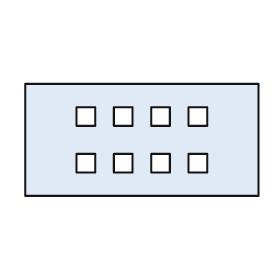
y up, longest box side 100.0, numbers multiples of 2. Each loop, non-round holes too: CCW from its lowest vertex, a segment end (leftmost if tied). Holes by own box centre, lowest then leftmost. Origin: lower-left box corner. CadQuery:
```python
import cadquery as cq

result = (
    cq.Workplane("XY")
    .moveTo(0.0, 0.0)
    .lineTo(100.0, 0.0)
    .lineTo(100.0, 48.0)
    .lineTo(0.0, 48.0)
    .close()
    .moveTo(22.0, 10.0)
    .lineTo(30.0, 10.0)
    .lineTo(30.0, 18.0)
    .lineTo(22.0, 18.0)
    .close()
    .moveTo(38.0, 10.0)
    .lineTo(46.0, 10.0)
    .lineTo(46.0, 18.0)
    .lineTo(38.0, 18.0)
    .close()
    .moveTo(54.0, 10.0)
    .lineTo(62.0, 10.0)
    .lineTo(62.0, 18.0)
    .lineTo(54.0, 18.0)
    .close()
    .moveTo(70.0, 10.0)
    .lineTo(78.0, 10.0)
    .lineTo(78.0, 18.0)
    .lineTo(70.0, 18.0)
    .close()
    .moveTo(22.0, 30.0)
    .lineTo(30.0, 30.0)
    .lineTo(30.0, 38.0)
    .lineTo(22.0, 38.0)
    .close()
    .moveTo(38.0, 30.0)
    .lineTo(46.0, 30.0)
    .lineTo(46.0, 38.0)
    .lineTo(38.0, 38.0)
    .close()
    .moveTo(54.0, 30.0)
    .lineTo(62.0, 30.0)
    .lineTo(62.0, 38.0)
    .lineTo(54.0, 38.0)
    .close()
    .moveTo(70.0, 30.0)
    .lineTo(78.0, 30.0)
    .lineTo(78.0, 38.0)
    .lineTo(70.0, 38.0)
    .close()
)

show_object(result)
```